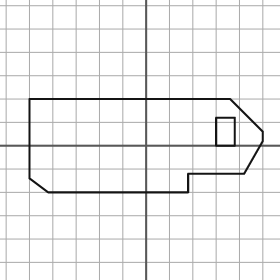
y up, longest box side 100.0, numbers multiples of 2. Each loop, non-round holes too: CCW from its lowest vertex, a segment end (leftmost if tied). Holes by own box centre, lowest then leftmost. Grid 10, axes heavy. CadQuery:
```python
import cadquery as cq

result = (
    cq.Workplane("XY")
    .moveTo(-42.0, -20.0)
    .lineTo(18.0, -20.0)
    .lineTo(18.0, -12.0)
    .lineTo(42.0, -12.0)
    .lineTo(50.0, 2.0)
    .lineTo(50.0, 6.0)
    .lineTo(36.0, 20.0)
    .lineTo(-50.0, 20.0)
    .lineTo(-50.0, -14.0)
    .close()
    .moveTo(30.0, 0.0)
    .lineTo(38.0, 0.0)
    .lineTo(38.0, 12.0)
    .lineTo(30.0, 12.0)
    .close()
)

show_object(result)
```